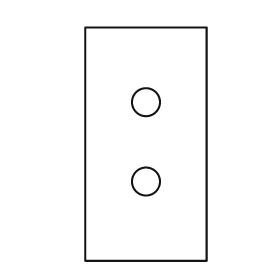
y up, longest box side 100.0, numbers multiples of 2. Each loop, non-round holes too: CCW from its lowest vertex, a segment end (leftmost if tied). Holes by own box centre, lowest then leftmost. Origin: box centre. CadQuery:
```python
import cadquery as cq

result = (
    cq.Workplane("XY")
    .moveTo(-26.0, -50.0)
    .lineTo(26.0, -50.0)
    .lineTo(26.0, 50.0)
    .lineTo(-26.0, 50.0)
    .close()
    .moveTo(0.0, -16.0)
    .circle(6.0)
    .moveTo(0.0, 18.0)
    .circle(6.0)
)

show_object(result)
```